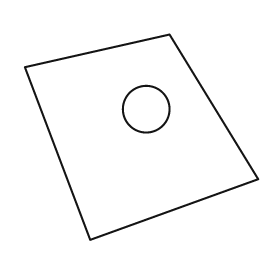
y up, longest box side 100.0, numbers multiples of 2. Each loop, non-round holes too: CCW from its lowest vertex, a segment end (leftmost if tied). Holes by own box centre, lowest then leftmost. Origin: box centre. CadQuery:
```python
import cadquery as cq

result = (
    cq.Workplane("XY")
    .moveTo(-22.0, -44.0)
    .lineTo(50.0, -18.0)
    .lineTo(12.0, 44.0)
    .lineTo(-50.0, 30.0)
    .close()
    .moveTo(2.0, 12.0)
    .circle(10.0)
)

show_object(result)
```